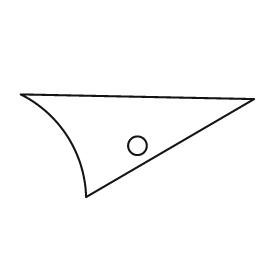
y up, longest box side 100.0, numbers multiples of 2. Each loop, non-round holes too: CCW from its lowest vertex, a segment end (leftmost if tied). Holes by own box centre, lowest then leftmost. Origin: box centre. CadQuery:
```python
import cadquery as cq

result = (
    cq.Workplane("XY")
    .moveTo(-22.0, -22.0)
    .lineTo(50.0, 20.0)
    .lineTo(-50.0, 22.0)
    .threePointArc((-30.0, 4.0), (-22.0, -22.0))
    .close()
    .moveTo(0.0, 0.0)
    .circle(4.0)
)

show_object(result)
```